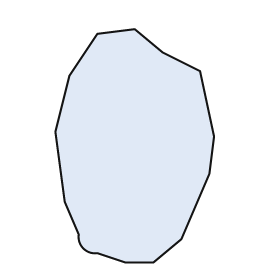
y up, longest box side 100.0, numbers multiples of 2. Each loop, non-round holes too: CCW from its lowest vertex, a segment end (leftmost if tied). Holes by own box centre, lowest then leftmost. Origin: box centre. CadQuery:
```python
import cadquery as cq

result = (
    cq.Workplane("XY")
    .moveTo(-4.0, -50.0)
    .lineTo(8.0, -50.0)
    .lineTo(20.0, -40.0)
    .lineTo(32.0, -12.0)
    .lineTo(34.0, 4.0)
    .lineTo(28.0, 32.0)
    .lineTo(12.0, 40.0)
    .lineTo(0.0, 50.0)
    .lineTo(-16.0, 48.0)
    .lineTo(-28.0, 30.0)
    .lineTo(-34.0, 6.0)
    .lineTo(-30.0, -24.0)
    .lineTo(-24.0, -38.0)
    .threePointArc((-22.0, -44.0), (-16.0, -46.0))
    .close()
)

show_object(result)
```